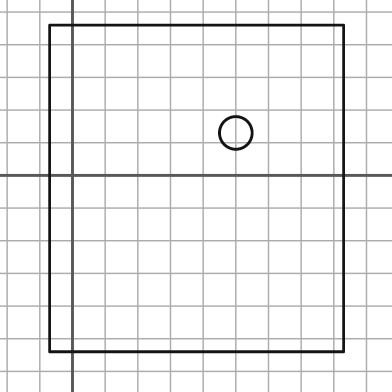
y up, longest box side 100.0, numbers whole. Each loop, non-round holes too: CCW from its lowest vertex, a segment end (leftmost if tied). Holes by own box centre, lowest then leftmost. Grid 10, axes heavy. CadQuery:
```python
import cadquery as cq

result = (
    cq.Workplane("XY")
    .moveTo(-7.0, -54.0)
    .lineTo(83.0, -54.0)
    .lineTo(83.0, 46.0)
    .lineTo(-7.0, 46.0)
    .close()
    .moveTo(50.0, 13.0)
    .circle(5.0)
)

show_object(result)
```